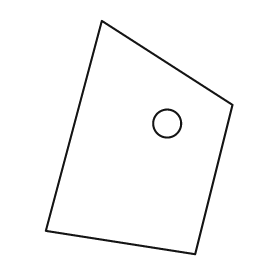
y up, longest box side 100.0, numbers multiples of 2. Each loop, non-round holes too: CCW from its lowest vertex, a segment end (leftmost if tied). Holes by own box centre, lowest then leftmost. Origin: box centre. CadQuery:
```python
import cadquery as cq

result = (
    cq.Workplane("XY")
    .moveTo(24.0, -50.0)
    .lineTo(40.0, 14.0)
    .lineTo(-16.0, 50.0)
    .lineTo(-40.0, -40.0)
    .close()
    .moveTo(12.0, 6.0)
    .circle(6.0)
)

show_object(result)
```